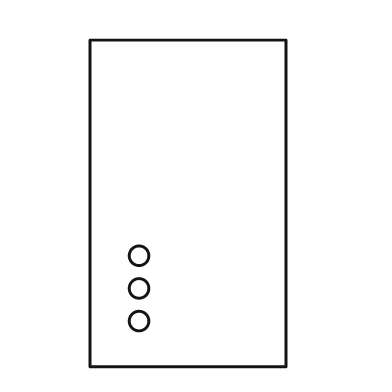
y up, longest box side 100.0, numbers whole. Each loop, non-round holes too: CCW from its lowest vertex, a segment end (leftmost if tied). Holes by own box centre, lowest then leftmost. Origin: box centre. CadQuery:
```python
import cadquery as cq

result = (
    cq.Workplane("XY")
    .moveTo(-30.0, -50.0)
    .lineTo(30.0, -50.0)
    .lineTo(30.0, 50.0)
    .lineTo(-30.0, 50.0)
    .close()
    .moveTo(-15.0, -36.0)
    .circle(3.0)
    .moveTo(-15.0, -26.0)
    .circle(3.0)
    .moveTo(-15.0, -16.0)
    .circle(3.0)
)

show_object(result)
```